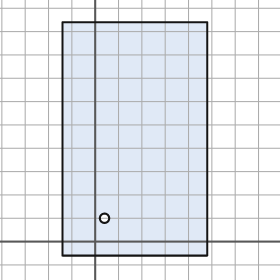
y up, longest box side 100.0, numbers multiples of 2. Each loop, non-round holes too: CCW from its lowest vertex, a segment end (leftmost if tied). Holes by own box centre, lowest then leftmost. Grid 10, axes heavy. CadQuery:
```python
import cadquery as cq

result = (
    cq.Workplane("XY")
    .moveTo(-14.0, -6.0)
    .lineTo(48.0, -6.0)
    .lineTo(48.0, 94.0)
    .lineTo(-14.0, 94.0)
    .close()
    .moveTo(4.0, 10.0)
    .circle(2.0)
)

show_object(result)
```